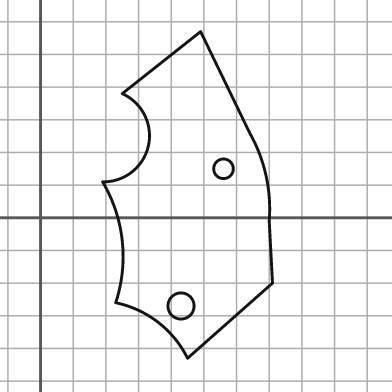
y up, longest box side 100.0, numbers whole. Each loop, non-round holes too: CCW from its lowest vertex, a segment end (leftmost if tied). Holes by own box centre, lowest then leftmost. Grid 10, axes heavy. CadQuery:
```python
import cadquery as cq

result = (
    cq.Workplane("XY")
    .moveTo(45.0, -43.0)
    .lineTo(71.0, -20.0)
    .lineTo(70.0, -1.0)
    .threePointArc((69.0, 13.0), (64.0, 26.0))
    .lineTo(49.0, 57.0)
    .lineTo(25.0, 38.0)
    .threePointArc((33.0, 22.0), (19.0, 11.0))
    .threePointArc((25.0, -7.0), (23.0, -26.0))
    .threePointArc((36.0, -32.0), (45.0, -43.0))
    .close()
    .moveTo(43.0, -27.0)
    .circle(4.0)
    .moveTo(56.0, 15.0)
    .circle(3.0)
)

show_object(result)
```